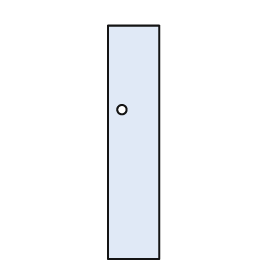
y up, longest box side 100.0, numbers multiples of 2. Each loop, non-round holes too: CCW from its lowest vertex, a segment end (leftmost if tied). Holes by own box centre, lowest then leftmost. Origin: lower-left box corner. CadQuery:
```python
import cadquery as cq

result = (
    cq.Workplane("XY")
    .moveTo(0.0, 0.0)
    .lineTo(22.0, 0.0)
    .lineTo(22.0, 100.0)
    .lineTo(0.0, 100.0)
    .close()
    .moveTo(6.0, 64.0)
    .circle(2.0)
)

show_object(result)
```